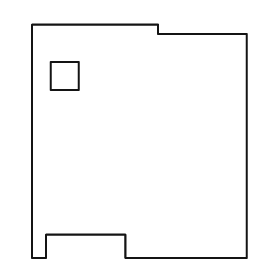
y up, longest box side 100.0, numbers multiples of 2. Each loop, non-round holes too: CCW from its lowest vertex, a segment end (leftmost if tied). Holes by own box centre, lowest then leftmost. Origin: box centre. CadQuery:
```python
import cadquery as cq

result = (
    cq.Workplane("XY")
    .moveTo(-46.0, -50.0)
    .lineTo(-40.0, -50.0)
    .lineTo(-40.0, -40.0)
    .lineTo(-6.0, -40.0)
    .lineTo(-6.0, -50.0)
    .lineTo(46.0, -50.0)
    .lineTo(46.0, 46.0)
    .lineTo(8.0, 46.0)
    .lineTo(8.0, 50.0)
    .lineTo(-46.0, 50.0)
    .close()
    .moveTo(-38.0, 22.0)
    .lineTo(-26.0, 22.0)
    .lineTo(-26.0, 34.0)
    .lineTo(-38.0, 34.0)
    .close()
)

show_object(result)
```